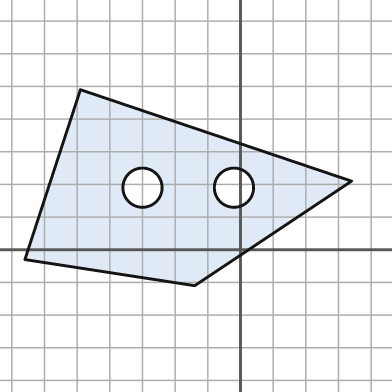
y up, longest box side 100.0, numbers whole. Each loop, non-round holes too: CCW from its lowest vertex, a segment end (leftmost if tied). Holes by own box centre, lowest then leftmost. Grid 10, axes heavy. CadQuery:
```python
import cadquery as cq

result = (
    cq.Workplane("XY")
    .moveTo(-14.0, -11.0)
    .lineTo(34.0, 21.0)
    .lineTo(-49.0, 49.0)
    .lineTo(-66.0, -3.0)
    .close()
    .moveTo(-30.0, 19.0)
    .circle(6.0)
    .moveTo(-2.0, 19.0)
    .circle(6.0)
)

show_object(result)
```